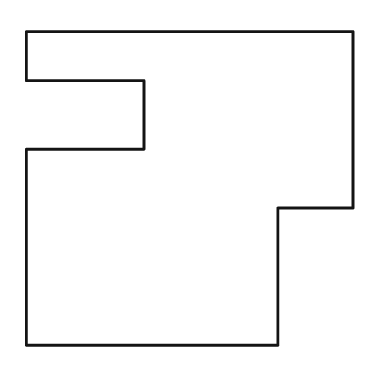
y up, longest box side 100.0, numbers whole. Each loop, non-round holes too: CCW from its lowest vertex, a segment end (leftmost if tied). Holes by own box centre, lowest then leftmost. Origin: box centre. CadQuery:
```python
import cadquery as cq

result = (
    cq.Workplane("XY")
    .moveTo(-50.0, -48.0)
    .lineTo(27.0, -48.0)
    .lineTo(27.0, -6.0)
    .lineTo(50.0, -6.0)
    .lineTo(50.0, 48.0)
    .lineTo(-50.0, 48.0)
    .lineTo(-50.0, 33.0)
    .lineTo(-14.0, 33.0)
    .lineTo(-14.0, 12.0)
    .lineTo(-50.0, 12.0)
    .close()
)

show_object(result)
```